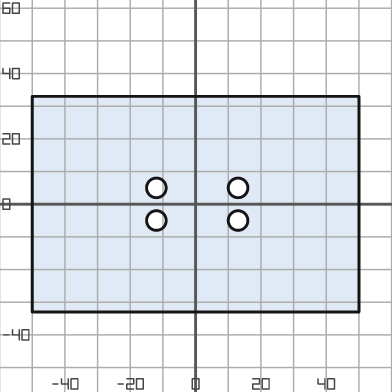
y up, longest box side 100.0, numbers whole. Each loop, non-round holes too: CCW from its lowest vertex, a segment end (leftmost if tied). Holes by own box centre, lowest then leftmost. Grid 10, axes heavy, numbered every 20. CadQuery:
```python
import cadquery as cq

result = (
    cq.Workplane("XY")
    .moveTo(-50.0, -33.0)
    .lineTo(50.0, -33.0)
    .lineTo(50.0, 33.0)
    .lineTo(-50.0, 33.0)
    .close()
    .moveTo(-12.0, -5.0)
    .circle(3.0)
    .moveTo(13.0, -5.0)
    .circle(3.0)
    .moveTo(-12.0, 5.0)
    .circle(3.0)
    .moveTo(13.0, 5.0)
    .circle(3.0)
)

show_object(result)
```